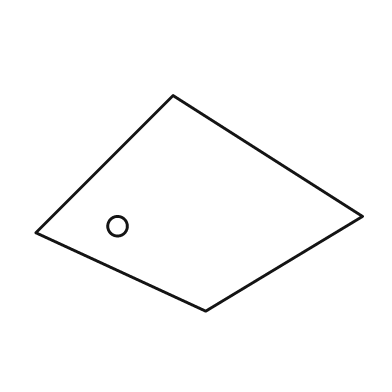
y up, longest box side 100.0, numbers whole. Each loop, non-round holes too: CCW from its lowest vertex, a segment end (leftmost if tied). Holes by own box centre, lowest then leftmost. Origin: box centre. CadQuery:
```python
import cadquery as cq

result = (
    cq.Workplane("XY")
    .moveTo(2.0, -33.0)
    .lineTo(50.0, -4.0)
    .lineTo(-8.0, 33.0)
    .lineTo(-50.0, -9.0)
    .close()
    .moveTo(-25.0, -7.0)
    .circle(3.0)
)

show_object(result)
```